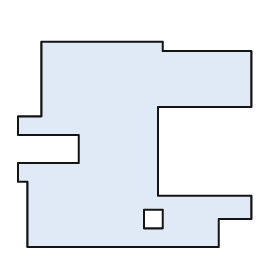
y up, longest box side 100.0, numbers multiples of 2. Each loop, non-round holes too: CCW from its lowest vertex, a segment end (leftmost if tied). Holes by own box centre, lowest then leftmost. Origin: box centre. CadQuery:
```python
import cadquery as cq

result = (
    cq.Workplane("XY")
    .moveTo(-46.0, -44.0)
    .lineTo(36.0, -44.0)
    .lineTo(36.0, -32.0)
    .lineTo(50.0, -32.0)
    .lineTo(50.0, -22.0)
    .lineTo(10.0, -22.0)
    .lineTo(10.0, 16.0)
    .lineTo(50.0, 16.0)
    .lineTo(50.0, 40.0)
    .lineTo(12.0, 40.0)
    .lineTo(12.0, 44.0)
    .lineTo(-40.0, 44.0)
    .lineTo(-40.0, 12.0)
    .lineTo(-50.0, 12.0)
    .lineTo(-50.0, 4.0)
    .lineTo(-24.0, 4.0)
    .lineTo(-24.0, -8.0)
    .lineTo(-50.0, -8.0)
    .lineTo(-50.0, -16.0)
    .lineTo(-46.0, -16.0)
    .close()
    .moveTo(4.0, -36.0)
    .lineTo(12.0, -36.0)
    .lineTo(12.0, -28.0)
    .lineTo(4.0, -28.0)
    .close()
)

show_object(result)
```